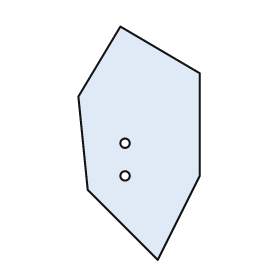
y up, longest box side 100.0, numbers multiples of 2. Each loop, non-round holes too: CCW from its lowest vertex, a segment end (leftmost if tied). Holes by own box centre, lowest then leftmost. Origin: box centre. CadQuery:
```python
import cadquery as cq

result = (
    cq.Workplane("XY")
    .moveTo(8.0, -50.0)
    .lineTo(26.0, -14.0)
    .lineTo(26.0, 30.0)
    .lineTo(-8.0, 50.0)
    .lineTo(-26.0, 20.0)
    .lineTo(-22.0, -20.0)
    .close()
    .moveTo(-6.0, -14.0)
    .circle(2.0)
    .moveTo(-6.0, 0.0)
    .circle(2.0)
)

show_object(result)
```